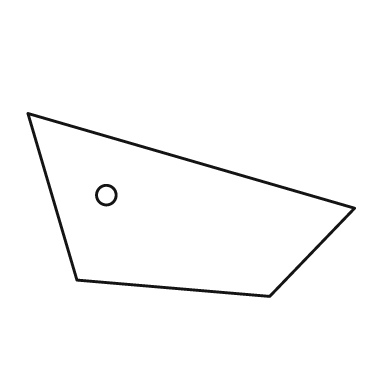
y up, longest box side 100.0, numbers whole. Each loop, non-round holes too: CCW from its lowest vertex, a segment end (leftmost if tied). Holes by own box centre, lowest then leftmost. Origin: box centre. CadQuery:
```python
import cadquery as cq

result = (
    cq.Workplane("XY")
    .moveTo(24.0, -28.0)
    .lineTo(50.0, -1.0)
    .lineTo(-50.0, 28.0)
    .lineTo(-35.0, -23.0)
    .close()
    .moveTo(-26.0, 3.0)
    .circle(3.0)
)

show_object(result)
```